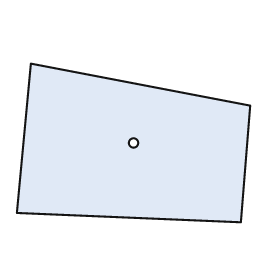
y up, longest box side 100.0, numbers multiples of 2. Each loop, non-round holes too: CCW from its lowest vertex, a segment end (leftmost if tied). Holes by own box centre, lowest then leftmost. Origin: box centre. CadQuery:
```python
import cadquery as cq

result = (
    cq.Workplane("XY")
    .moveTo(46.0, -34.0)
    .lineTo(50.0, 16.0)
    .lineTo(-44.0, 34.0)
    .lineTo(-50.0, -30.0)
    .close()
    .moveTo(0.0, 0.0)
    .circle(2.0)
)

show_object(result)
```